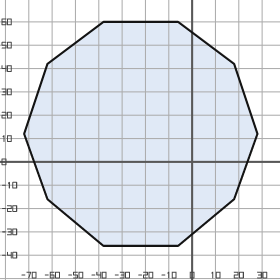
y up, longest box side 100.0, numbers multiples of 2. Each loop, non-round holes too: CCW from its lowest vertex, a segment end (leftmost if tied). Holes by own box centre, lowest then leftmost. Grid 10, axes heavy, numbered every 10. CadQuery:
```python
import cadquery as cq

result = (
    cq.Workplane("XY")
    .moveTo(-38.0, -36.0)
    .lineTo(-6.0, -36.0)
    .lineTo(18.0, -16.0)
    .lineTo(28.0, 12.0)
    .lineTo(18.0, 42.0)
    .lineTo(-6.0, 60.0)
    .lineTo(-38.0, 60.0)
    .lineTo(-62.0, 42.0)
    .lineTo(-72.0, 12.0)
    .lineTo(-62.0, -16.0)
    .close()
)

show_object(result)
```